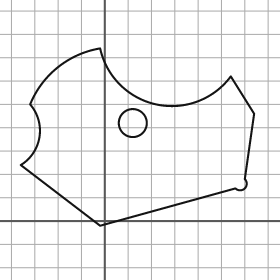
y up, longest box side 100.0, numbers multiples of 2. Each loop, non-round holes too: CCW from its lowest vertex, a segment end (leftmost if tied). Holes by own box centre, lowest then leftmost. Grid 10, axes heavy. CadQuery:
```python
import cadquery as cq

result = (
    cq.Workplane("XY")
    .moveTo(-2.0, -2.0)
    .lineTo(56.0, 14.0)
    .threePointArc((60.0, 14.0), (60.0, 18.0))
    .lineTo(64.0, 46.0)
    .lineTo(54.0, 62.0)
    .threePointArc((22.0, 50.0), (-2.0, 74.0))
    .threePointArc((-20.0, 66.0), (-32.0, 50.0))
    .threePointArc((-28.0, 36.0), (-36.0, 24.0))
    .close()
    .moveTo(12.0, 42.0)
    .circle(6.0)
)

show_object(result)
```